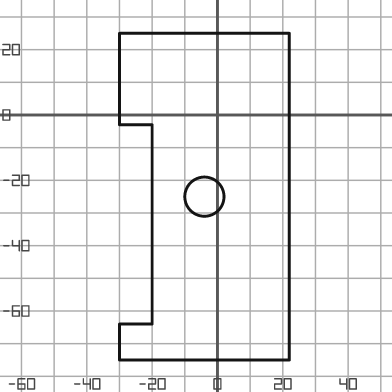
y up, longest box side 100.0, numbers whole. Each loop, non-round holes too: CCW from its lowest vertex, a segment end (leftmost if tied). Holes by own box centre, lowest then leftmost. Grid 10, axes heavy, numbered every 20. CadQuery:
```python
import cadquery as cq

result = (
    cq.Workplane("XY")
    .moveTo(-30.0, -75.0)
    .lineTo(22.0, -75.0)
    .lineTo(22.0, 25.0)
    .lineTo(-30.0, 25.0)
    .lineTo(-30.0, -3.0)
    .lineTo(-20.0, -3.0)
    .lineTo(-20.0, -64.0)
    .lineTo(-30.0, -64.0)
    .close()
    .moveTo(-4.0, -25.0)
    .circle(6.0)
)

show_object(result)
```